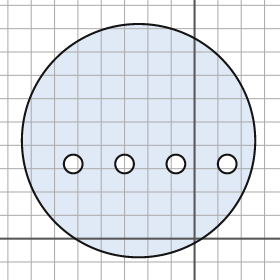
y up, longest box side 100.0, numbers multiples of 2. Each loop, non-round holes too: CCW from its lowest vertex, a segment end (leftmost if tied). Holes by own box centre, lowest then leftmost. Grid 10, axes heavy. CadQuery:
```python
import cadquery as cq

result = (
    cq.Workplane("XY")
    .moveTo(-24.0, 42.0)
    .circle(50.0)
    .moveTo(-52.0, 32.0)
    .circle(4.0)
    .moveTo(-30.0, 32.0)
    .circle(4.0)
    .moveTo(-8.0, 32.0)
    .circle(4.0)
    .moveTo(14.0, 32.0)
    .circle(4.0)
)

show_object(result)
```